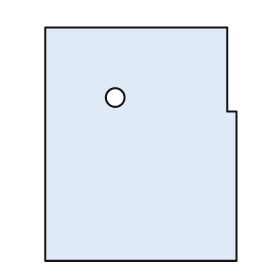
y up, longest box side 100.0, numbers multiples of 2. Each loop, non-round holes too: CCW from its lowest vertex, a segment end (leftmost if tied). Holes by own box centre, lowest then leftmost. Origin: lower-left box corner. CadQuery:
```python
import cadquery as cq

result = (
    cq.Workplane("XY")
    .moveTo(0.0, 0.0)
    .lineTo(82.0, 0.0)
    .lineTo(82.0, 64.0)
    .lineTo(78.0, 64.0)
    .lineTo(78.0, 100.0)
    .lineTo(0.0, 100.0)
    .close()
    .moveTo(30.0, 70.0)
    .circle(4.0)
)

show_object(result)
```